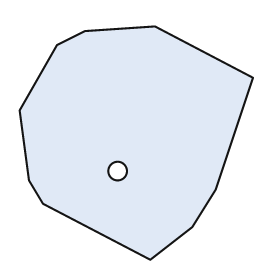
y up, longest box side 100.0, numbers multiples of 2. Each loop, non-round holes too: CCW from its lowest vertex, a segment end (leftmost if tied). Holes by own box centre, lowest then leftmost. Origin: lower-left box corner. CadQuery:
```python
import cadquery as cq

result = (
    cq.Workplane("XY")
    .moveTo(56.0, 0.0)
    .lineTo(74.0, 14.0)
    .lineTo(84.0, 30.0)
    .lineTo(100.0, 78.0)
    .lineTo(58.0, 100.0)
    .lineTo(28.0, 98.0)
    .lineTo(16.0, 92.0)
    .lineTo(0.0, 64.0)
    .lineTo(4.0, 34.0)
    .lineTo(10.0, 24.0)
    .close()
    .moveTo(42.0, 38.0)
    .circle(4.0)
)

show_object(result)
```